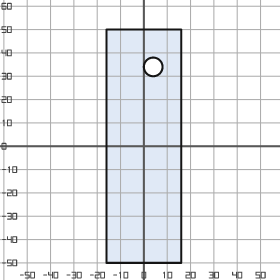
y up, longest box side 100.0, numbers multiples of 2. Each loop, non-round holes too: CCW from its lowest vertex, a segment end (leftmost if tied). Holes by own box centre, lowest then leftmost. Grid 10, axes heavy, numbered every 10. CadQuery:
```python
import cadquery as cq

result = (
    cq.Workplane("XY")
    .moveTo(-16.0, -50.0)
    .lineTo(16.0, -50.0)
    .lineTo(16.0, 50.0)
    .lineTo(-16.0, 50.0)
    .close()
    .moveTo(4.0, 34.0)
    .circle(4.0)
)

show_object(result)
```